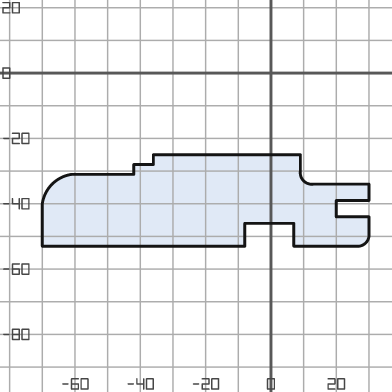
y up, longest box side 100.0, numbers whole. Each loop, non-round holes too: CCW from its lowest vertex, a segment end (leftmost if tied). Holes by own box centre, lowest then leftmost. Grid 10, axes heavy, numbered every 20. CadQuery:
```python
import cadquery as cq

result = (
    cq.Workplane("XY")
    .moveTo(-70.0, -53.0)
    .lineTo(-8.0, -53.0)
    .lineTo(-8.0, -46.0)
    .lineTo(7.0, -46.0)
    .lineTo(7.0, -53.0)
    .lineTo(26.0, -53.0)
    .threePointArc((29.0, -52.0), (30.0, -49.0))
    .lineTo(30.0, -44.0)
    .lineTo(20.0, -44.0)
    .lineTo(20.0, -39.0)
    .lineTo(30.0, -39.0)
    .lineTo(30.0, -34.0)
    .lineTo(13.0, -34.0)
    .threePointArc((10.0, -33.0), (9.0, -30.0))
    .lineTo(9.0, -25.0)
    .lineTo(-36.0, -25.0)
    .lineTo(-36.0, -28.0)
    .lineTo(-42.0, -28.0)
    .lineTo(-42.0, -31.0)
    .lineTo(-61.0, -31.0)
    .threePointArc((-67.0, -34.0), (-70.0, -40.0))
    .close()
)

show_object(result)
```